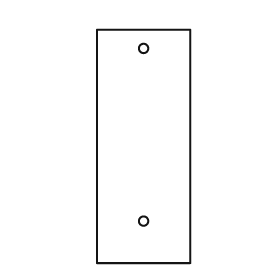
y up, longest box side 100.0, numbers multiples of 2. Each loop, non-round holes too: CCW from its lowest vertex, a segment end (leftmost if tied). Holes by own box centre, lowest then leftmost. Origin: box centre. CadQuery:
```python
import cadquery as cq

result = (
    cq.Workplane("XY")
    .moveTo(-20.0, -50.0)
    .lineTo(20.0, -50.0)
    .lineTo(20.0, 50.0)
    .lineTo(-20.0, 50.0)
    .close()
    .moveTo(0.0, -32.0)
    .circle(2.0)
    .moveTo(0.0, 42.0)
    .circle(2.0)
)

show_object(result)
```